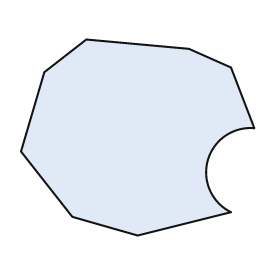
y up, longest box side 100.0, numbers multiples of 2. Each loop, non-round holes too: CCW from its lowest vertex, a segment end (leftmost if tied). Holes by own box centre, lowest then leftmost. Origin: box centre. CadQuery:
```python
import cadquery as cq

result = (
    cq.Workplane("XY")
    .moveTo(0.0, -42.0)
    .lineTo(40.0, -32.0)
    .threePointArc((30.0, -10.0), (50.0, 4.0))
    .lineTo(40.0, 30.0)
    .lineTo(22.0, 38.0)
    .lineTo(-22.0, 42.0)
    .lineTo(-40.0, 28.0)
    .lineTo(-50.0, -6.0)
    .lineTo(-28.0, -34.0)
    .close()
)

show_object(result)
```